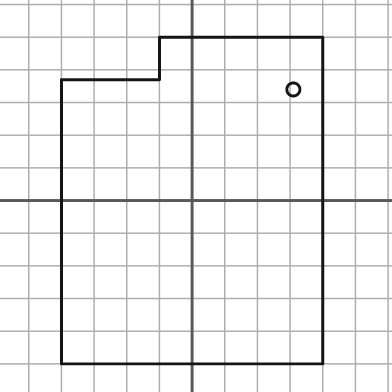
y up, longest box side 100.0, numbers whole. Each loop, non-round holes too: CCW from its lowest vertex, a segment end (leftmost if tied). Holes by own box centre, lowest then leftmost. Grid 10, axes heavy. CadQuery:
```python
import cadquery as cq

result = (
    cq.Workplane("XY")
    .moveTo(-40.0, -50.0)
    .lineTo(40.0, -50.0)
    .lineTo(40.0, 50.0)
    .lineTo(-10.0, 50.0)
    .lineTo(-10.0, 37.0)
    .lineTo(-40.0, 37.0)
    .close()
    .moveTo(31.0, 34.0)
    .circle(2.0)
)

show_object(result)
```